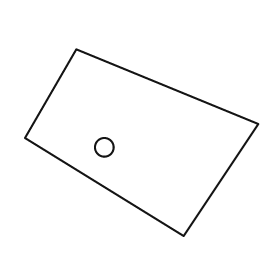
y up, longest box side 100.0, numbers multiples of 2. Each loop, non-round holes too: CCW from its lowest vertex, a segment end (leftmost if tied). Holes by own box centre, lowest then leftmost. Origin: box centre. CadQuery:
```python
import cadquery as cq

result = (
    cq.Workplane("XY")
    .moveTo(18.0, -40.0)
    .lineTo(50.0, 8.0)
    .lineTo(-28.0, 40.0)
    .lineTo(-50.0, 2.0)
    .close()
    .moveTo(-16.0, -2.0)
    .circle(4.0)
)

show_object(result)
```